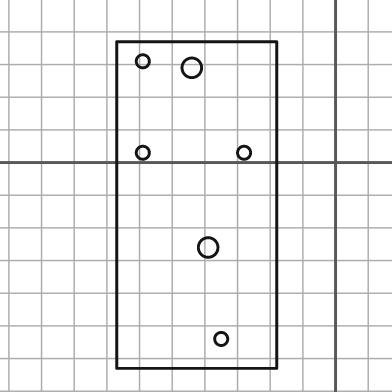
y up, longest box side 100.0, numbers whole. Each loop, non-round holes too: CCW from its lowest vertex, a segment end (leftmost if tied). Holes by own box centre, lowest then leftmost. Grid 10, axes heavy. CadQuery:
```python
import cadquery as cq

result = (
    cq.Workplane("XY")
    .moveTo(-67.0, -63.0)
    .lineTo(-18.0, -63.0)
    .lineTo(-18.0, 37.0)
    .lineTo(-67.0, 37.0)
    .close()
    .moveTo(-35.0, -54.0)
    .circle(2.0)
    .moveTo(-39.0, -26.0)
    .circle(3.0)
    .moveTo(-59.0, 3.0)
    .circle(2.0)
    .moveTo(-28.0, 3.0)
    .circle(2.0)
    .moveTo(-44.0, 29.0)
    .circle(3.0)
    .moveTo(-59.0, 31.0)
    .circle(2.0)
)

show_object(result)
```